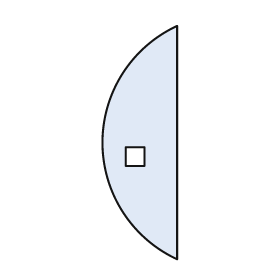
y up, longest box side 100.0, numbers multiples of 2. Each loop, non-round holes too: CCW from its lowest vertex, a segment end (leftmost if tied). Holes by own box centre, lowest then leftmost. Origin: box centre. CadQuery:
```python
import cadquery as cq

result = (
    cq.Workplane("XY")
    .moveTo(16.0, -50.0)
    .lineTo(16.0, 50.0)
    .threePointArc((-16.0, 0.0), (16.0, -50.0))
    .close()
    .moveTo(-6.0, -10.0)
    .lineTo(2.0, -10.0)
    .lineTo(2.0, -2.0)
    .lineTo(-6.0, -2.0)
    .close()
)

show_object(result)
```